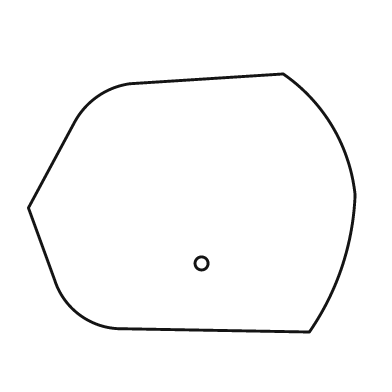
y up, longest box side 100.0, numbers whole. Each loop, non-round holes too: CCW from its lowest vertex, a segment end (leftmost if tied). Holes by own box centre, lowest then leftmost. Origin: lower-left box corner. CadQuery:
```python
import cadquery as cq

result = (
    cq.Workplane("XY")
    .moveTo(86.0, 0.0)
    .threePointArc((96.0, 20.0), (100.0, 42.0))
    .threePointArc((93.0, 63.0), (78.0, 79.0))
    .lineTo(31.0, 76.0)
    .threePointArc((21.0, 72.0), (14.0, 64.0))
    .lineTo(0.0, 38.0)
    .lineTo(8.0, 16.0)
    .threePointArc((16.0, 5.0), (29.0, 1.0))
    .close()
    .moveTo(53.0, 21.0)
    .circle(2.0)
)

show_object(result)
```